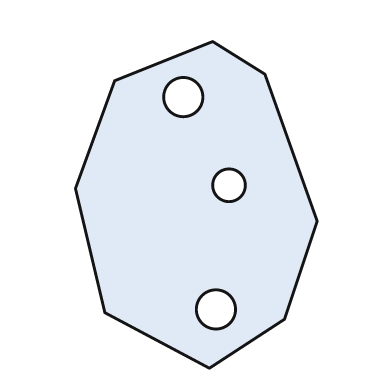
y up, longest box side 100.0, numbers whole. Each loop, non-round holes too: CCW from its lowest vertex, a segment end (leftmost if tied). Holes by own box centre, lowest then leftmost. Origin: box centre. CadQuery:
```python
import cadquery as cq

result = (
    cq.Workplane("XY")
    .moveTo(4.0, -50.0)
    .lineTo(27.0, -35.0)
    .lineTo(37.0, -5.0)
    .lineTo(21.0, 40.0)
    .lineTo(5.0, 50.0)
    .lineTo(-25.0, 38.0)
    .lineTo(-37.0, 5.0)
    .lineTo(-28.0, -33.0)
    .close()
    .moveTo(6.0, -32.0)
    .circle(6.0)
    .moveTo(10.0, 6.0)
    .circle(5.0)
    .moveTo(-4.0, 33.0)
    .circle(6.0)
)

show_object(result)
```